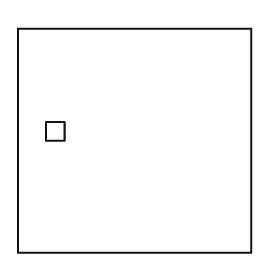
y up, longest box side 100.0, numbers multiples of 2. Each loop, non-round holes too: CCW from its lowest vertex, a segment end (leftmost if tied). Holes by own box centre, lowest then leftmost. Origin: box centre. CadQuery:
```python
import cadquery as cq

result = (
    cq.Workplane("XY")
    .moveTo(-50.0, -48.0)
    .lineTo(50.0, -48.0)
    .lineTo(50.0, 48.0)
    .lineTo(-50.0, 48.0)
    .close()
    .moveTo(-38.0, 0.0)
    .lineTo(-30.0, 0.0)
    .lineTo(-30.0, 8.0)
    .lineTo(-38.0, 8.0)
    .close()
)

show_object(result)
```